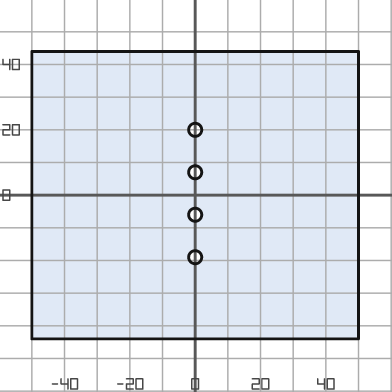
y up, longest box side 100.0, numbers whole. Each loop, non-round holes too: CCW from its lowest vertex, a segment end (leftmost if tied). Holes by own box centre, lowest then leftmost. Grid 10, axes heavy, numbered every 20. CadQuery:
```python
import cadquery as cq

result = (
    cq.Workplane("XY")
    .moveTo(-50.0, -44.0)
    .lineTo(50.0, -44.0)
    .lineTo(50.0, 44.0)
    .lineTo(-50.0, 44.0)
    .close()
    .moveTo(0.0, -19.0)
    .circle(2.0)
    .moveTo(0.0, -6.0)
    .circle(2.0)
    .moveTo(0.0, 7.0)
    .circle(2.0)
    .moveTo(0.0, 20.0)
    .circle(2.0)
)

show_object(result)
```